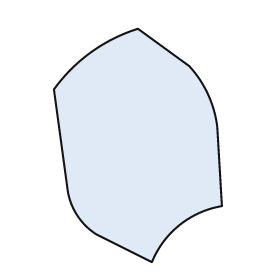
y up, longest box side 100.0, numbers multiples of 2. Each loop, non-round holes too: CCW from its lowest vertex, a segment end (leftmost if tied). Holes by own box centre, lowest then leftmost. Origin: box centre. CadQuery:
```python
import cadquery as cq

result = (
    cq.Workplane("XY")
    .moveTo(6.0, -50.0)
    .threePointArc((18.0, -34.0), (36.0, -26.0))
    .lineTo(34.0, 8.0)
    .threePointArc((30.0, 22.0), (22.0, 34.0))
    .lineTo(0.0, 50.0)
    .threePointArc((-20.0, 40.0), (-36.0, 24.0))
    .lineTo(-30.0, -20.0)
    .threePointArc((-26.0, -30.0), (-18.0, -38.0))
    .close()
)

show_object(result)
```